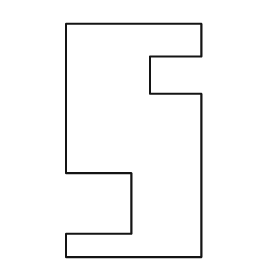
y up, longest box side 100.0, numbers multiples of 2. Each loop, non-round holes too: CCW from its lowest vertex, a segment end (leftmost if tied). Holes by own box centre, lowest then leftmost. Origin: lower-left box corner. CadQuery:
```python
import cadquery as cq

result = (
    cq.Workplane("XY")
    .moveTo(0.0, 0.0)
    .lineTo(58.0, 0.0)
    .lineTo(58.0, 70.0)
    .lineTo(36.0, 70.0)
    .lineTo(36.0, 86.0)
    .lineTo(58.0, 86.0)
    .lineTo(58.0, 100.0)
    .lineTo(0.0, 100.0)
    .lineTo(0.0, 36.0)
    .lineTo(28.0, 36.0)
    .lineTo(28.0, 10.0)
    .lineTo(0.0, 10.0)
    .close()
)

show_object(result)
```